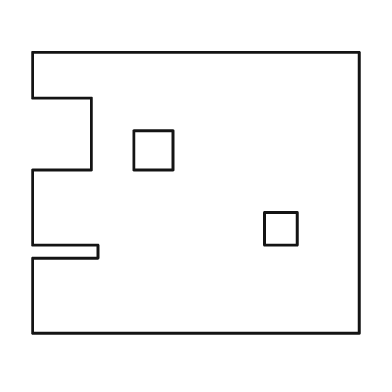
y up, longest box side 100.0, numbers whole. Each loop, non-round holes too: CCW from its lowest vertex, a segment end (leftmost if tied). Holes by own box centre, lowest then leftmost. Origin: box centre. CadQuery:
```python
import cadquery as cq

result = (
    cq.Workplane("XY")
    .moveTo(-50.0, -43.0)
    .lineTo(50.0, -43.0)
    .lineTo(50.0, 43.0)
    .lineTo(-50.0, 43.0)
    .lineTo(-50.0, 29.0)
    .lineTo(-32.0, 29.0)
    .lineTo(-32.0, 7.0)
    .lineTo(-50.0, 7.0)
    .lineTo(-50.0, -16.0)
    .lineTo(-30.0, -16.0)
    .lineTo(-30.0, -20.0)
    .lineTo(-50.0, -20.0)
    .close()
    .moveTo(21.0, -16.0)
    .lineTo(31.0, -16.0)
    .lineTo(31.0, -6.0)
    .lineTo(21.0, -6.0)
    .close()
    .moveTo(-19.0, 7.0)
    .lineTo(-7.0, 7.0)
    .lineTo(-7.0, 19.0)
    .lineTo(-19.0, 19.0)
    .close()
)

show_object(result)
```